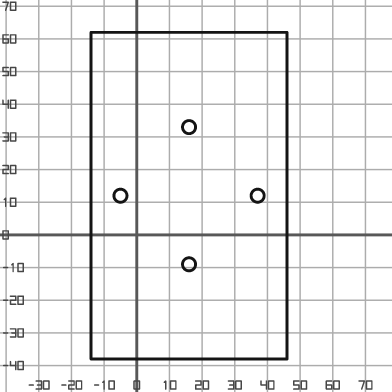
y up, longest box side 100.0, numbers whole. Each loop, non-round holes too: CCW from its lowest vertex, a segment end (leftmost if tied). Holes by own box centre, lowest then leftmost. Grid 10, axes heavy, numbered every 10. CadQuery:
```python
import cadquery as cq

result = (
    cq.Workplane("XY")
    .moveTo(-14.0, -38.0)
    .lineTo(46.0, -38.0)
    .lineTo(46.0, 62.0)
    .lineTo(-14.0, 62.0)
    .close()
    .moveTo(16.0, -9.0)
    .circle(2.0)
    .moveTo(-5.0, 12.0)
    .circle(2.0)
    .moveTo(37.0, 12.0)
    .circle(2.0)
    .moveTo(16.0, 33.0)
    .circle(2.0)
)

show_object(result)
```